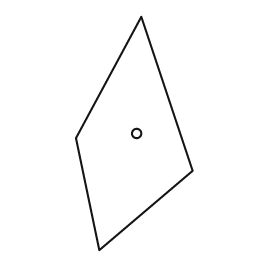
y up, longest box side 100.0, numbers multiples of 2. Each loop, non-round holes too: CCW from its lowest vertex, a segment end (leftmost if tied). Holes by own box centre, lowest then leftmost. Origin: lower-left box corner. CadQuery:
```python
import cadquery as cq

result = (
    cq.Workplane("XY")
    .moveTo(10.0, 0.0)
    .lineTo(50.0, 34.0)
    .lineTo(28.0, 100.0)
    .lineTo(0.0, 48.0)
    .close()
    .moveTo(26.0, 50.0)
    .circle(2.0)
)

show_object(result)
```